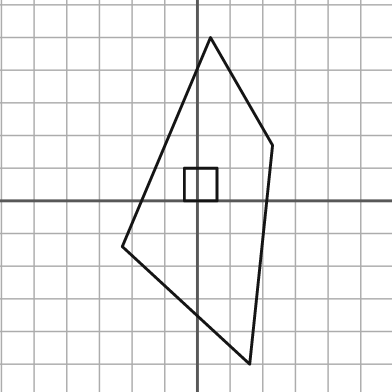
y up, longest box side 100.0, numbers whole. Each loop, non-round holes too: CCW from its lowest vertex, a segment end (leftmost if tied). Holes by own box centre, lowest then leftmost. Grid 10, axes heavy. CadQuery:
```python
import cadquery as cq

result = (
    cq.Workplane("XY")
    .moveTo(16.0, -50.0)
    .lineTo(23.0, 17.0)
    .lineTo(4.0, 50.0)
    .lineTo(-23.0, -14.0)
    .close()
    .moveTo(-4.0, 0.0)
    .lineTo(6.0, 0.0)
    .lineTo(6.0, 10.0)
    .lineTo(-4.0, 10.0)
    .close()
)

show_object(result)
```